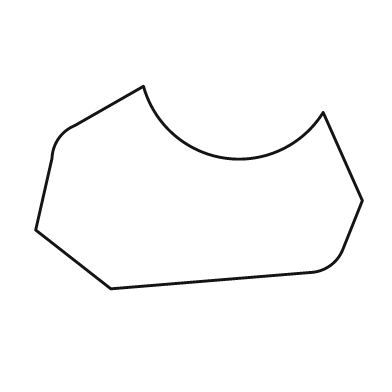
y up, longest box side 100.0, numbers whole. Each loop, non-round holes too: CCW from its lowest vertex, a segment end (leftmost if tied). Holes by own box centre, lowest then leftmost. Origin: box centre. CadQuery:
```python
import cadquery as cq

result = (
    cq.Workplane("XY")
    .moveTo(-27.0, -31.0)
    .lineTo(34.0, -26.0)
    .threePointArc((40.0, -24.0), (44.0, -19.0))
    .lineTo(50.0, -4.0)
    .lineTo(38.0, 23.0)
    .threePointArc((8.0, 9.0), (-17.0, 31.0))
    .lineTo(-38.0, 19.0)
    .threePointArc((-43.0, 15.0), (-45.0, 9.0))
    .lineTo(-50.0, -13.0)
    .close()
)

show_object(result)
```